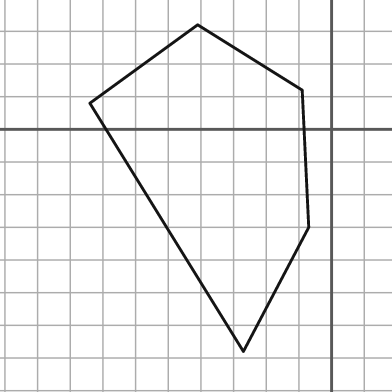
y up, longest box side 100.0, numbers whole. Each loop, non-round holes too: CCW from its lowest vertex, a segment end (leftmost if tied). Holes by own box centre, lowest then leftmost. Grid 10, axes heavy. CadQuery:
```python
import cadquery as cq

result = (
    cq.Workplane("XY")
    .moveTo(-27.0, -68.0)
    .lineTo(-7.0, -30.0)
    .lineTo(-9.0, 12.0)
    .lineTo(-41.0, 32.0)
    .lineTo(-74.0, 8.0)
    .close()
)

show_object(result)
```